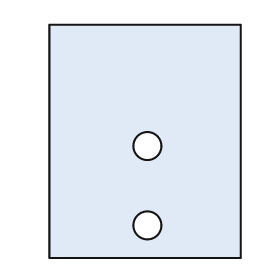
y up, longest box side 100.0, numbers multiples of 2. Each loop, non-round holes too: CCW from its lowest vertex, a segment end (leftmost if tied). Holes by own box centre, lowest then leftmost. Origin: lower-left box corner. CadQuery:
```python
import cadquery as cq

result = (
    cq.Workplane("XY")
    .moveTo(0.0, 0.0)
    .lineTo(82.0, 0.0)
    .lineTo(82.0, 100.0)
    .lineTo(0.0, 100.0)
    .close()
    .moveTo(42.0, 14.0)
    .circle(6.0)
    .moveTo(42.0, 48.0)
    .circle(6.0)
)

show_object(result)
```